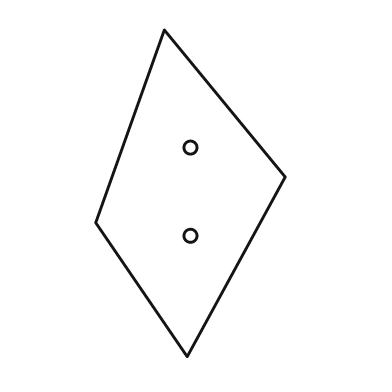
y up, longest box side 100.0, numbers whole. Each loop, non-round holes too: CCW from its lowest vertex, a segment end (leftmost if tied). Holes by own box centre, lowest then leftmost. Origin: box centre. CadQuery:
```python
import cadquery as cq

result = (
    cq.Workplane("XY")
    .moveTo(-1.0, -50.0)
    .lineTo(29.0, 5.0)
    .lineTo(-8.0, 50.0)
    .lineTo(-29.0, -9.0)
    .close()
    .moveTo(0.0, -13.0)
    .circle(2.0)
    .moveTo(0.0, 14.0)
    .circle(2.0)
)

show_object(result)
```